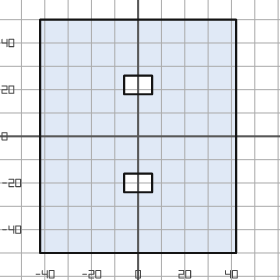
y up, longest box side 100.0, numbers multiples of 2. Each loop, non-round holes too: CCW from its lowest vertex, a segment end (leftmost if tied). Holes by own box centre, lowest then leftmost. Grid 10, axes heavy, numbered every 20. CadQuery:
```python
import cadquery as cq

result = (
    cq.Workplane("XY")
    .moveTo(-42.0, -50.0)
    .lineTo(42.0, -50.0)
    .lineTo(42.0, 50.0)
    .lineTo(-42.0, 50.0)
    .close()
    .moveTo(-6.0, -24.0)
    .lineTo(6.0, -24.0)
    .lineTo(6.0, -16.0)
    .lineTo(-6.0, -16.0)
    .close()
    .moveTo(-6.0, 18.0)
    .lineTo(6.0, 18.0)
    .lineTo(6.0, 26.0)
    .lineTo(-6.0, 26.0)
    .close()
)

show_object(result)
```